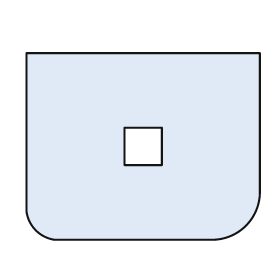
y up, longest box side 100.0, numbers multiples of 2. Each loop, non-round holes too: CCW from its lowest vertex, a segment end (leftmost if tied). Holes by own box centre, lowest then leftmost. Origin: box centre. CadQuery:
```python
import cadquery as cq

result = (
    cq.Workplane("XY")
    .moveTo(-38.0, -40.0)
    .lineTo(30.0, -40.0)
    .threePointArc((44.0, -34.0), (50.0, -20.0))
    .lineTo(50.0, 40.0)
    .lineTo(-50.0, 40.0)
    .lineTo(-50.0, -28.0)
    .threePointArc((-46.0, -36.0), (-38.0, -40.0))
    .close()
    .moveTo(-8.0, -8.0)
    .lineTo(8.0, -8.0)
    .lineTo(8.0, 8.0)
    .lineTo(-8.0, 8.0)
    .close()
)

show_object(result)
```